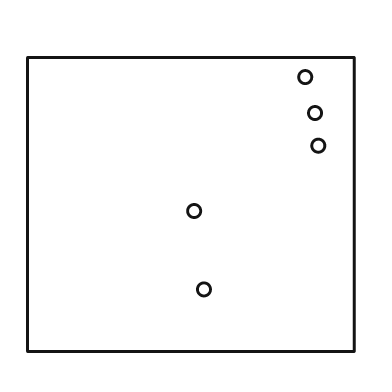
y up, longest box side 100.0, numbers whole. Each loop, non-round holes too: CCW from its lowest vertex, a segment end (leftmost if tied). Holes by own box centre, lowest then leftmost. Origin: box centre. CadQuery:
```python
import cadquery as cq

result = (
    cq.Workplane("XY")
    .moveTo(-50.0, -45.0)
    .lineTo(50.0, -45.0)
    .lineTo(50.0, 45.0)
    .lineTo(-50.0, 45.0)
    .close()
    .moveTo(4.0, -26.0)
    .circle(2.0)
    .moveTo(1.0, -2.0)
    .circle(2.0)
    .moveTo(39.0, 18.0)
    .circle(2.0)
    .moveTo(38.0, 28.0)
    .circle(2.0)
    .moveTo(35.0, 39.0)
    .circle(2.0)
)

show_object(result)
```